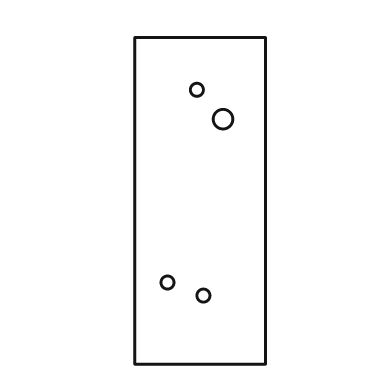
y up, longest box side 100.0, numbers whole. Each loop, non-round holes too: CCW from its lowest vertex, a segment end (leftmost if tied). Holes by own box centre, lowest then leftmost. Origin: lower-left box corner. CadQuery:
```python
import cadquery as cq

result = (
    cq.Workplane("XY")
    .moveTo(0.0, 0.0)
    .lineTo(40.0, 0.0)
    .lineTo(40.0, 100.0)
    .lineTo(0.0, 100.0)
    .close()
    .moveTo(21.0, 21.0)
    .circle(2.0)
    .moveTo(10.0, 25.0)
    .circle(2.0)
    .moveTo(27.0, 75.0)
    .circle(3.0)
    .moveTo(19.0, 84.0)
    .circle(2.0)
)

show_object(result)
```